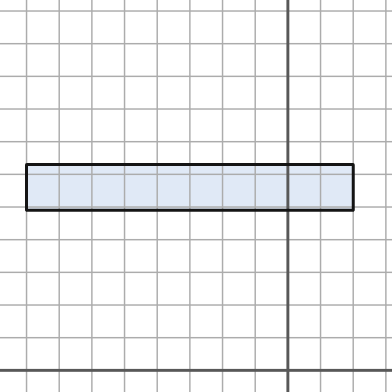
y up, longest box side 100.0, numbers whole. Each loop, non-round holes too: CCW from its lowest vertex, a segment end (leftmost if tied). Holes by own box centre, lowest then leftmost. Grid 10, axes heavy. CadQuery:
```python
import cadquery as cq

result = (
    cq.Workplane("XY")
    .moveTo(-80.0, 49.0)
    .lineTo(20.0, 49.0)
    .lineTo(20.0, 63.0)
    .lineTo(-80.0, 63.0)
    .close()
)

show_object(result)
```